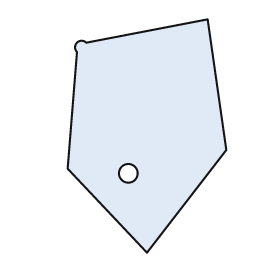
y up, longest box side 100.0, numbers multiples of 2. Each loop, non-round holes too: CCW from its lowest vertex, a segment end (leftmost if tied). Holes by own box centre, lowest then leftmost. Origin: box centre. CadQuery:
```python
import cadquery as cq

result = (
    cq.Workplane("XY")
    .moveTo(0.0, -50.0)
    .lineTo(34.0, -6.0)
    .lineTo(26.0, 50.0)
    .lineTo(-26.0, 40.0)
    .threePointArc((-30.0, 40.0), (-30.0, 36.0))
    .lineTo(-34.0, -14.0)
    .close()
    .moveTo(-8.0, -16.0)
    .circle(4.0)
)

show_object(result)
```